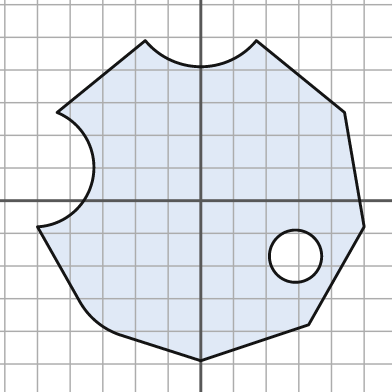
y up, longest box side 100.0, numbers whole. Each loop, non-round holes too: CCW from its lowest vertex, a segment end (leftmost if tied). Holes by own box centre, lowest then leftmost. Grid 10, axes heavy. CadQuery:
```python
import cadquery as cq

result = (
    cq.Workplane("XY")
    .moveTo(0.0, -49.0)
    .lineTo(33.0, -38.0)
    .lineTo(50.0, -8.0)
    .lineTo(44.0, 27.0)
    .lineTo(17.0, 49.0)
    .threePointArc((0.0, 41.0), (-17.0, 49.0))
    .lineTo(-44.0, 27.0)
    .threePointArc((-33.0, 7.0), (-50.0, -8.0))
    .lineTo(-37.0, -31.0)
    .threePointArc((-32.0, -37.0), (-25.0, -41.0))
    .close()
    .moveTo(29.0, -17.0)
    .circle(8.0)
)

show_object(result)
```